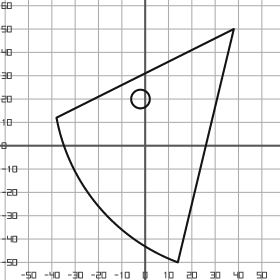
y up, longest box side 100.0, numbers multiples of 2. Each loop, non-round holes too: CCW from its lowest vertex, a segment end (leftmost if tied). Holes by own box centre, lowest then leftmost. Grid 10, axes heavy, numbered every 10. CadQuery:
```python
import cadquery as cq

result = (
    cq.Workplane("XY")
    .moveTo(14.0, -50.0)
    .lineTo(38.0, 50.0)
    .lineTo(-38.0, 12.0)
    .threePointArc((-20.0, -26.0), (14.0, -50.0))
    .close()
    .moveTo(-2.0, 20.0)
    .circle(4.0)
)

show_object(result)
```